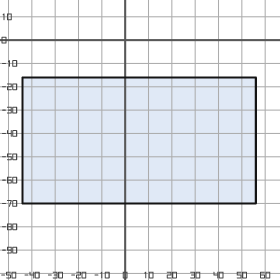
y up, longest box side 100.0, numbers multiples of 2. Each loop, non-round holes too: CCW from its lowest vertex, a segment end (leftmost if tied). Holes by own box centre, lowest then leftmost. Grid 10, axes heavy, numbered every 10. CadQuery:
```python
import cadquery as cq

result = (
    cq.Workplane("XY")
    .moveTo(-44.0, -70.0)
    .lineTo(56.0, -70.0)
    .lineTo(56.0, -16.0)
    .lineTo(-44.0, -16.0)
    .close()
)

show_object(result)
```